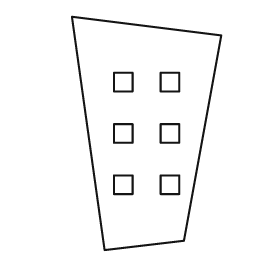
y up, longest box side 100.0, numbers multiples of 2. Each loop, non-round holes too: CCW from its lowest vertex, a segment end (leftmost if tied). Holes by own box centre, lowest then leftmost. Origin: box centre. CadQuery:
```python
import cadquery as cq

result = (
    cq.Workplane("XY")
    .moveTo(-18.0, -50.0)
    .lineTo(16.0, -46.0)
    .lineTo(32.0, 42.0)
    .lineTo(-32.0, 50.0)
    .close()
    .moveTo(-14.0, -26.0)
    .lineTo(-6.0, -26.0)
    .lineTo(-6.0, -18.0)
    .lineTo(-14.0, -18.0)
    .close()
    .moveTo(6.0, -26.0)
    .lineTo(14.0, -26.0)
    .lineTo(14.0, -18.0)
    .lineTo(6.0, -18.0)
    .close()
    .moveTo(-14.0, -4.0)
    .lineTo(-6.0, -4.0)
    .lineTo(-6.0, 4.0)
    .lineTo(-14.0, 4.0)
    .close()
    .moveTo(6.0, -4.0)
    .lineTo(14.0, -4.0)
    .lineTo(14.0, 4.0)
    .lineTo(6.0, 4.0)
    .close()
    .moveTo(-14.0, 18.0)
    .lineTo(-6.0, 18.0)
    .lineTo(-6.0, 26.0)
    .lineTo(-14.0, 26.0)
    .close()
    .moveTo(6.0, 18.0)
    .lineTo(14.0, 18.0)
    .lineTo(14.0, 26.0)
    .lineTo(6.0, 26.0)
    .close()
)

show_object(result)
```